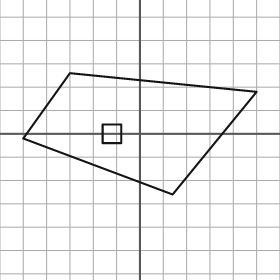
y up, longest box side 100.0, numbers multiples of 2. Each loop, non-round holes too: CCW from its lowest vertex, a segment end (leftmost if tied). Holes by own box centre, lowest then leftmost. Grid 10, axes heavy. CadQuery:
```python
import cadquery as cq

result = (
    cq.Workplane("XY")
    .moveTo(14.0, -26.0)
    .lineTo(50.0, 18.0)
    .lineTo(-30.0, 26.0)
    .lineTo(-50.0, -2.0)
    .close()
    .moveTo(-16.0, -4.0)
    .lineTo(-8.0, -4.0)
    .lineTo(-8.0, 4.0)
    .lineTo(-16.0, 4.0)
    .close()
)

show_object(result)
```